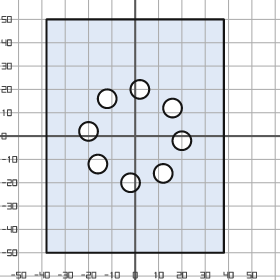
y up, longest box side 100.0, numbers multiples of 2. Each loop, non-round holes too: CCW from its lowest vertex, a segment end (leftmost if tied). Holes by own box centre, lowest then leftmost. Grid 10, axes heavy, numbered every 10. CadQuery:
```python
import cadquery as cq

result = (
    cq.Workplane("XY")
    .moveTo(-38.0, -50.0)
    .lineTo(38.0, -50.0)
    .lineTo(38.0, 50.0)
    .lineTo(-38.0, 50.0)
    .close()
    .moveTo(-2.0, -20.0)
    .circle(4.0)
    .moveTo(12.0, -16.0)
    .circle(4.0)
    .moveTo(-16.0, -12.0)
    .circle(4.0)
    .moveTo(20.0, -2.0)
    .circle(4.0)
    .moveTo(-20.0, 2.0)
    .circle(4.0)
    .moveTo(16.0, 12.0)
    .circle(4.0)
    .moveTo(-12.0, 16.0)
    .circle(4.0)
    .moveTo(2.0, 20.0)
    .circle(4.0)
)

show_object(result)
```